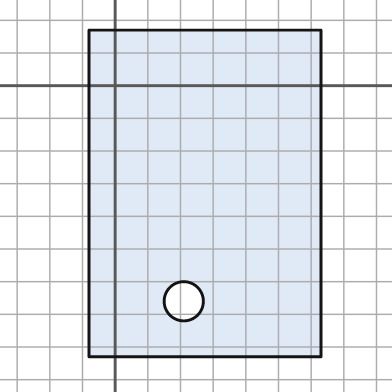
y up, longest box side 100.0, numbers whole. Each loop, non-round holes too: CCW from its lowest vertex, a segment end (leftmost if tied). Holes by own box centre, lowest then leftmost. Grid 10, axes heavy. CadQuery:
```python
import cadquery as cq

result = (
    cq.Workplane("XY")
    .moveTo(-8.0, -83.0)
    .lineTo(63.0, -83.0)
    .lineTo(63.0, 17.0)
    .lineTo(-8.0, 17.0)
    .close()
    .moveTo(21.0, -66.0)
    .circle(6.0)
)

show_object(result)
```